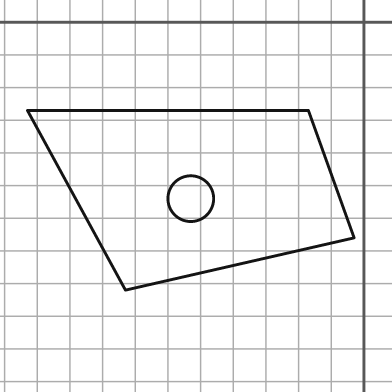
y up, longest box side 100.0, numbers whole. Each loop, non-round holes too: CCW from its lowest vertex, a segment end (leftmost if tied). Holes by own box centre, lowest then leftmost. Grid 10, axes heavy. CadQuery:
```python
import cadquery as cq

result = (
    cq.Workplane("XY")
    .moveTo(-73.0, -82.0)
    .lineTo(-3.0, -66.0)
    .lineTo(-17.0, -27.0)
    .lineTo(-103.0, -27.0)
    .close()
    .moveTo(-53.0, -54.0)
    .circle(7.0)
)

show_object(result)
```